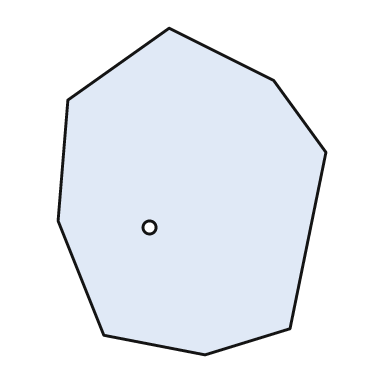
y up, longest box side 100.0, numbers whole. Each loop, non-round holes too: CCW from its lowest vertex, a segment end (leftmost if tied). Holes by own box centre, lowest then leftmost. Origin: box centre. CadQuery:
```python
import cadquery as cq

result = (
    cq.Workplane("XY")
    .moveTo(4.0, -50.0)
    .lineTo(30.0, -42.0)
    .lineTo(41.0, 12.0)
    .lineTo(25.0, 34.0)
    .lineTo(-7.0, 50.0)
    .lineTo(-38.0, 28.0)
    .lineTo(-41.0, -9.0)
    .lineTo(-27.0, -44.0)
    .close()
    .moveTo(-13.0, -11.0)
    .circle(2.0)
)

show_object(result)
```